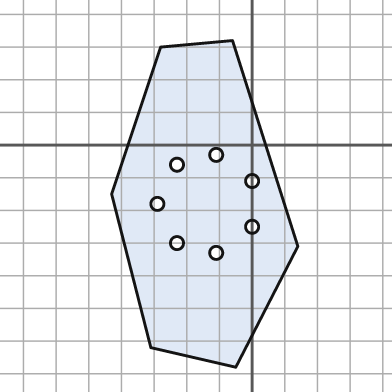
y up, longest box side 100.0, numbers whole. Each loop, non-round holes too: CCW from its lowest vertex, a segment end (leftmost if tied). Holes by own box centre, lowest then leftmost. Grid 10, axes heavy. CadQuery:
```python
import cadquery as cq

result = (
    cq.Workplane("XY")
    .moveTo(-5.0, -68.0)
    .lineTo(14.0, -31.0)
    .lineTo(-6.0, 32.0)
    .lineTo(-28.0, 30.0)
    .lineTo(-43.0, -15.0)
    .lineTo(-31.0, -62.0)
    .close()
    .moveTo(-11.0, -33.0)
    .circle(2.0)
    .moveTo(-23.0, -30.0)
    .circle(2.0)
    .moveTo(0.0, -25.0)
    .circle(2.0)
    .moveTo(-29.0, -18.0)
    .circle(2.0)
    .moveTo(0.0, -11.0)
    .circle(2.0)
    .moveTo(-23.0, -6.0)
    .circle(2.0)
    .moveTo(-11.0, -3.0)
    .circle(2.0)
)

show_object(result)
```